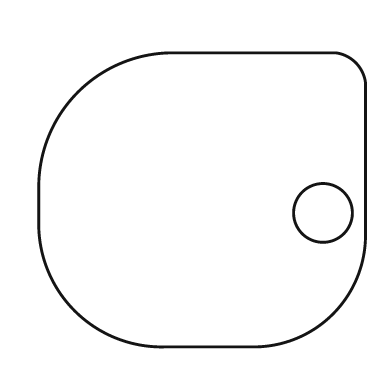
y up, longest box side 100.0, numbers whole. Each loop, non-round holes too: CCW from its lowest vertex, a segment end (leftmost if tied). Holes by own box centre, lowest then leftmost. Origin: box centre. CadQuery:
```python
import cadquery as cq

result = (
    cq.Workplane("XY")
    .moveTo(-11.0, -45.0)
    .lineTo(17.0, -45.0)
    .threePointArc((40.0, -35.0), (50.0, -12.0))
    .lineTo(50.0, 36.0)
    .threePointArc((47.0, 42.0), (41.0, 45.0))
    .lineTo(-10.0, 45.0)
    .threePointArc((-38.0, 33.0), (-50.0, 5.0))
    .lineTo(-50.0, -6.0)
    .threePointArc((-39.0, -34.0), (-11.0, -45.0))
    .close()
    .moveTo(37.0, -4.0)
    .circle(9.0)
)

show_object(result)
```